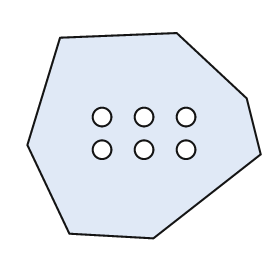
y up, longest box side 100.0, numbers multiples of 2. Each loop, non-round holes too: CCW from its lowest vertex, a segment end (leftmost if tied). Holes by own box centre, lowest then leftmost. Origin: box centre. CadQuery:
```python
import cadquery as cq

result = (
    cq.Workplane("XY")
    .moveTo(4.0, -44.0)
    .lineTo(50.0, -8.0)
    .lineTo(44.0, 16.0)
    .lineTo(14.0, 44.0)
    .lineTo(-36.0, 42.0)
    .lineTo(-50.0, -4.0)
    .lineTo(-32.0, -42.0)
    .close()
    .moveTo(-18.0, -6.0)
    .circle(4.0)
    .moveTo(0.0, -6.0)
    .circle(4.0)
    .moveTo(18.0, -6.0)
    .circle(4.0)
    .moveTo(-18.0, 8.0)
    .circle(4.0)
    .moveTo(0.0, 8.0)
    .circle(4.0)
    .moveTo(18.0, 8.0)
    .circle(4.0)
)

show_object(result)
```